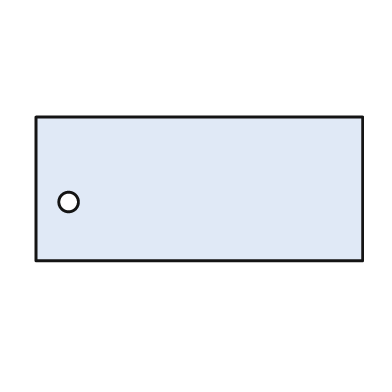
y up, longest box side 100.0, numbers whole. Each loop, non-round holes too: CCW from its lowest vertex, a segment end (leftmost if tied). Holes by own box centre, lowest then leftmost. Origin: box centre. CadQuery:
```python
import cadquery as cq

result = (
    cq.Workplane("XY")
    .moveTo(-50.0, -22.0)
    .lineTo(50.0, -22.0)
    .lineTo(50.0, 22.0)
    .lineTo(-50.0, 22.0)
    .close()
    .moveTo(-40.0, -4.0)
    .circle(3.0)
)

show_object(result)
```